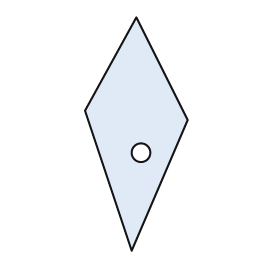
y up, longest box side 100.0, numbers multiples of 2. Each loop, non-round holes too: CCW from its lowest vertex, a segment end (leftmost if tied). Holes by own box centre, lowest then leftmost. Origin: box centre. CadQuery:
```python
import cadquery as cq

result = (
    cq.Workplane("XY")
    .moveTo(-2.0, -50.0)
    .lineTo(22.0, 6.0)
    .lineTo(0.0, 50.0)
    .lineTo(-22.0, 10.0)
    .close()
    .moveTo(2.0, -8.0)
    .circle(4.0)
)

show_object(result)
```